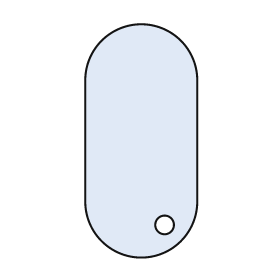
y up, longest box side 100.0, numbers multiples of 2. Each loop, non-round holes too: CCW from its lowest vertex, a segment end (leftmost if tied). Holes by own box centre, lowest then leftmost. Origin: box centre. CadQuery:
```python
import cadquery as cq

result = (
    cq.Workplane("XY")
    .moveTo(-24.0, -26.0)
    .threePointArc((0.0, -50.0), (24.0, -26.0))
    .lineTo(24.0, 26.0)
    .threePointArc((0.0, 50.0), (-24.0, 26.0))
    .close()
    .moveTo(10.0, -36.0)
    .circle(4.0)
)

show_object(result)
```